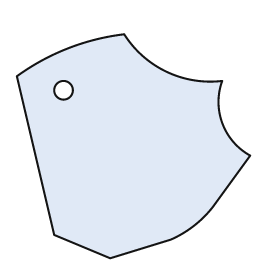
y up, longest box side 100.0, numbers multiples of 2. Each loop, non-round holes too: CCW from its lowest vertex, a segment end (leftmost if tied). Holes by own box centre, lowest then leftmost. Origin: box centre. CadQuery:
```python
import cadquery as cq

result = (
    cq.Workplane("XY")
    .moveTo(-10.0, -48.0)
    .lineTo(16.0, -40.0)
    .threePointArc((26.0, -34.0), (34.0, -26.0))
    .lineTo(50.0, -4.0)
    .threePointArc((38.0, 10.0), (38.0, 28.0))
    .threePointArc((14.0, 32.0), (-4.0, 48.0))
    .threePointArc((-28.0, 42.0), (-50.0, 30.0))
    .lineTo(-34.0, -38.0)
    .close()
    .moveTo(-30.0, 24.0)
    .circle(4.0)
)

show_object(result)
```